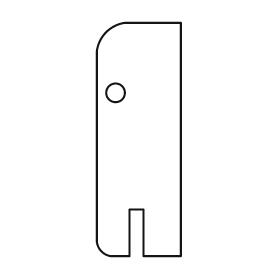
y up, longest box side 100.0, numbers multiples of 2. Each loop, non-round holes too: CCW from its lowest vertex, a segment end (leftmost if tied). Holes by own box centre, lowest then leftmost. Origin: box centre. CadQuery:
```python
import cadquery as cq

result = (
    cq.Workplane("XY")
    .moveTo(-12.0, -50.0)
    .lineTo(-4.0, -50.0)
    .lineTo(-4.0, -30.0)
    .lineTo(2.0, -30.0)
    .lineTo(2.0, -50.0)
    .lineTo(18.0, -50.0)
    .lineTo(18.0, 50.0)
    .lineTo(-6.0, 50.0)
    .threePointArc((-14.0, 46.0), (-18.0, 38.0))
    .lineTo(-18.0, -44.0)
    .threePointArc((-16.0, -48.0), (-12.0, -50.0))
    .close()
    .moveTo(-10.0, 20.0)
    .circle(4.0)
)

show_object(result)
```